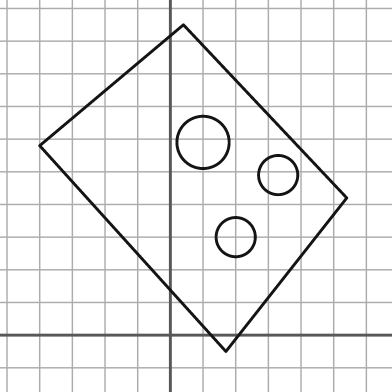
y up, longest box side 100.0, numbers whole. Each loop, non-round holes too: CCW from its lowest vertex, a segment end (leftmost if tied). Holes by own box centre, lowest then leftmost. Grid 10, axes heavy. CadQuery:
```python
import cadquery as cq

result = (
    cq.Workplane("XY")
    .moveTo(17.0, -5.0)
    .lineTo(54.0, 42.0)
    .lineTo(4.0, 95.0)
    .lineTo(-40.0, 58.0)
    .close()
    .moveTo(20.0, 30.0)
    .circle(6.0)
    .moveTo(33.0, 49.0)
    .circle(6.0)
    .moveTo(10.0, 59.0)
    .circle(8.0)
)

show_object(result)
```